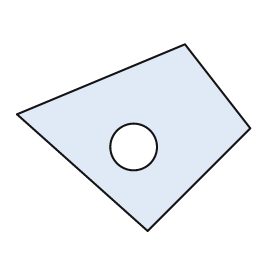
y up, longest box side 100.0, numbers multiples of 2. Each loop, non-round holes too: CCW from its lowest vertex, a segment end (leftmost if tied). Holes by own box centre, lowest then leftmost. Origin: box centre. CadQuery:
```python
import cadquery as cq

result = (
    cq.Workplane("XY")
    .moveTo(6.0, -40.0)
    .lineTo(50.0, 4.0)
    .lineTo(22.0, 40.0)
    .lineTo(-50.0, 10.0)
    .close()
    .moveTo(0.0, -4.0)
    .circle(10.0)
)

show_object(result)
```